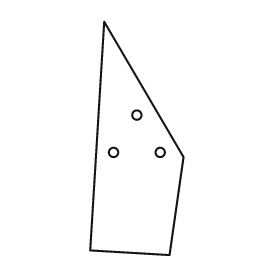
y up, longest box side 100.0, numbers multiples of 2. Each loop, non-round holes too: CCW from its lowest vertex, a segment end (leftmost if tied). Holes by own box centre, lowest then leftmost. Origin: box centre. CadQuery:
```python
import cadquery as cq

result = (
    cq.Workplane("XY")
    .moveTo(14.0, -50.0)
    .lineTo(20.0, -8.0)
    .lineTo(-14.0, 50.0)
    .lineTo(-20.0, -48.0)
    .close()
    .moveTo(-10.0, -6.0)
    .circle(2.0)
    .moveTo(10.0, -6.0)
    .circle(2.0)
    .moveTo(0.0, 10.0)
    .circle(2.0)
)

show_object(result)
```